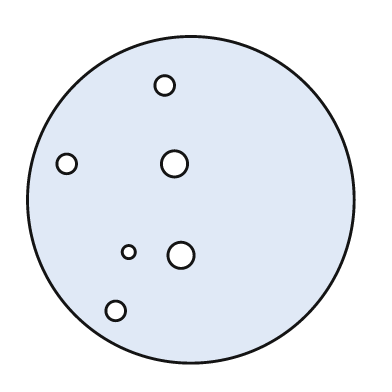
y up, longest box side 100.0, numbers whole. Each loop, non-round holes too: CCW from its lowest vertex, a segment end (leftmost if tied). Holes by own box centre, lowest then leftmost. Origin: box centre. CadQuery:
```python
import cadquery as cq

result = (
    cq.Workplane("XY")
    .moveTo(0.0, 0.0)
    .circle(50.0)
    .moveTo(-23.0, -34.0)
    .circle(3.0)
    .moveTo(-3.0, -17.0)
    .circle(4.0)
    .moveTo(-19.0, -16.0)
    .circle(2.0)
    .moveTo(-38.0, 11.0)
    .circle(3.0)
    .moveTo(-5.0, 11.0)
    .circle(4.0)
    .moveTo(-8.0, 35.0)
    .circle(3.0)
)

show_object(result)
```